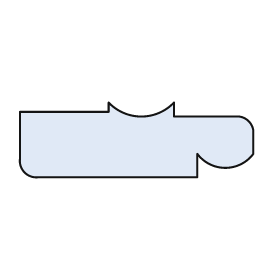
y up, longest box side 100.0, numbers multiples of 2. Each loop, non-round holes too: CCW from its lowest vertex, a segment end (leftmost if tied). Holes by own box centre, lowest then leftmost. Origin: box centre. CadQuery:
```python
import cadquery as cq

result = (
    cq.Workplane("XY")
    .moveTo(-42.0, -16.0)
    .lineTo(26.0, -16.0)
    .lineTo(26.0, -6.0)
    .threePointArc((38.0, -12.0), (50.0, -6.0))
    .lineTo(50.0, 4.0)
    .threePointArc((48.0, 8.0), (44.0, 10.0))
    .lineTo(16.0, 10.0)
    .lineTo(16.0, 16.0)
    .threePointArc((2.0, 10.0), (-12.0, 16.0))
    .lineTo(-12.0, 12.0)
    .lineTo(-50.0, 12.0)
    .lineTo(-50.0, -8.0)
    .threePointArc((-48.0, -14.0), (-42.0, -16.0))
    .close()
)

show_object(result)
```